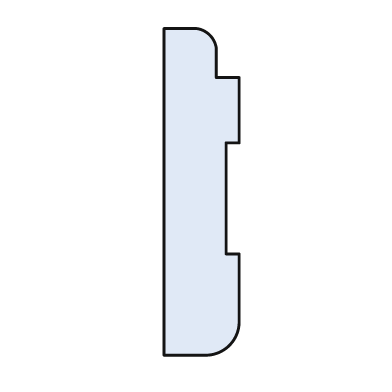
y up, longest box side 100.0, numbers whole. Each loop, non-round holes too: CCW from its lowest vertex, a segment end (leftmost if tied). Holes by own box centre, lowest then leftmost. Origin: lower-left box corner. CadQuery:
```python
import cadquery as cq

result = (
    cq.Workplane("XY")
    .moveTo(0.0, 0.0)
    .lineTo(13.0, 0.0)
    .threePointArc((20.0, 3.0), (23.0, 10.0))
    .lineTo(23.0, 31.0)
    .lineTo(19.0, 31.0)
    .lineTo(19.0, 65.0)
    .lineTo(23.0, 65.0)
    .lineTo(23.0, 85.0)
    .lineTo(16.0, 85.0)
    .lineTo(16.0, 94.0)
    .threePointArc((14.0, 98.0), (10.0, 100.0))
    .lineTo(0.0, 100.0)
    .close()
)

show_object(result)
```